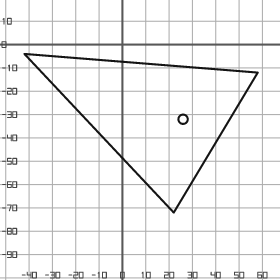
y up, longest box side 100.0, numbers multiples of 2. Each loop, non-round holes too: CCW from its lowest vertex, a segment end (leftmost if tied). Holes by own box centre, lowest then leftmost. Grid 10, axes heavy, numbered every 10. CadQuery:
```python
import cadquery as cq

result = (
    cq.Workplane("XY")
    .moveTo(22.0, -72.0)
    .lineTo(58.0, -12.0)
    .lineTo(-42.0, -4.0)
    .close()
    .moveTo(26.0, -32.0)
    .circle(2.0)
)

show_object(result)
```